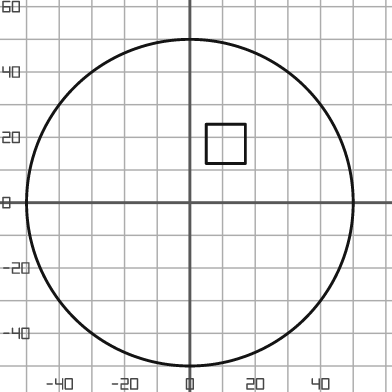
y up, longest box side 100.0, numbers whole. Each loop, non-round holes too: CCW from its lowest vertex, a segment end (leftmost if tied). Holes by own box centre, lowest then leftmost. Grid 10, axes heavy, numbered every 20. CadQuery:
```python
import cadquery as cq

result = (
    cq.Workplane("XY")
    .moveTo(0.0, 0.0)
    .circle(50.0)
    .moveTo(5.0, 12.0)
    .lineTo(17.0, 12.0)
    .lineTo(17.0, 24.0)
    .lineTo(5.0, 24.0)
    .close()
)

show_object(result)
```